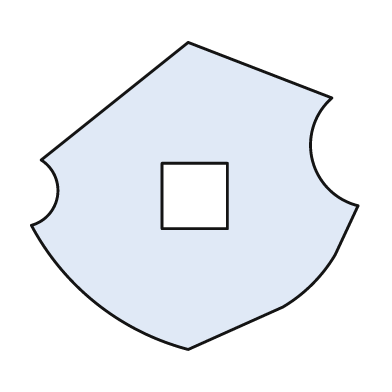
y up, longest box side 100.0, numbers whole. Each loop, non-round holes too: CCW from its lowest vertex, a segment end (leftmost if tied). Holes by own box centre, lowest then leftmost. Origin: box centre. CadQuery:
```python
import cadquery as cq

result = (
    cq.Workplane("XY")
    .moveTo(-2.0, -47.0)
    .lineTo(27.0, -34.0)
    .threePointArc((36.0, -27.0), (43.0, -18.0))
    .lineTo(50.0, -3.0)
    .threePointArc((36.0, 11.0), (42.0, 30.0))
    .lineTo(-2.0, 47.0)
    .lineTo(-47.0, 11.0)
    .threePointArc((-42.0, 0.0), (-50.0, -9.0))
    .threePointArc((-30.0, -33.0), (-2.0, -47.0))
    .close()
    .moveTo(-10.0, -10.0)
    .lineTo(10.0, -10.0)
    .lineTo(10.0, 10.0)
    .lineTo(-10.0, 10.0)
    .close()
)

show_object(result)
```